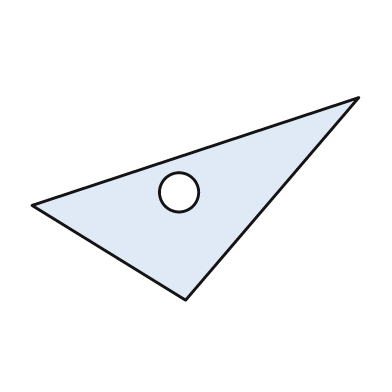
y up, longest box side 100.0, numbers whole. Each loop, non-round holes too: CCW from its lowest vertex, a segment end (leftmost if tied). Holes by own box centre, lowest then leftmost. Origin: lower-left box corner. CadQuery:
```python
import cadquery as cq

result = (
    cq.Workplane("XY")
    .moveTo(47.0, 0.0)
    .lineTo(100.0, 62.0)
    .lineTo(0.0, 29.0)
    .close()
    .moveTo(45.0, 33.0)
    .circle(6.0)
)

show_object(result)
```